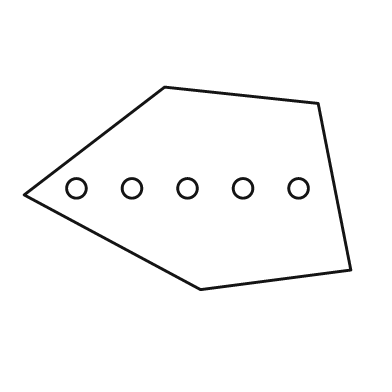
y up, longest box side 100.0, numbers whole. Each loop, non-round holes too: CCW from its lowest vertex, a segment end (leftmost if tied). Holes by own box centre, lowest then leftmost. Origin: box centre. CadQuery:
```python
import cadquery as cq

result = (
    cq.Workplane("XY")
    .moveTo(4.0, -31.0)
    .lineTo(50.0, -25.0)
    .lineTo(40.0, 26.0)
    .lineTo(-7.0, 31.0)
    .lineTo(-50.0, -2.0)
    .close()
    .moveTo(-34.0, 0.0)
    .circle(3.0)
    .moveTo(-17.0, 0.0)
    .circle(3.0)
    .moveTo(0.0, 0.0)
    .circle(3.0)
    .moveTo(17.0, 0.0)
    .circle(3.0)
    .moveTo(34.0, 0.0)
    .circle(3.0)
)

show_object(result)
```